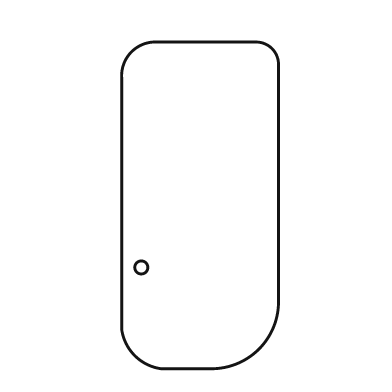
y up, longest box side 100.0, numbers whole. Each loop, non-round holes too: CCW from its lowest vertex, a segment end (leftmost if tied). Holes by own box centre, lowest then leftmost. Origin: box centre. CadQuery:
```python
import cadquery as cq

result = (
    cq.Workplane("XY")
    .moveTo(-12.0, -50.0)
    .lineTo(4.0, -50.0)
    .threePointArc((18.0, -44.0), (24.0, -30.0))
    .lineTo(24.0, 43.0)
    .threePointArc((22.0, 48.0), (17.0, 50.0))
    .lineTo(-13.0, 50.0)
    .threePointArc((-21.0, 47.0), (-24.0, 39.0))
    .lineTo(-24.0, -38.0)
    .threePointArc((-20.0, -46.0), (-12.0, -50.0))
    .close()
    .moveTo(-18.0, -19.0)
    .circle(2.0)
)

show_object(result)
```